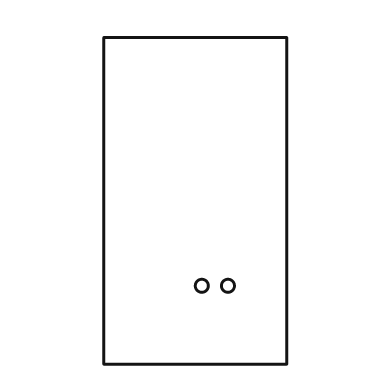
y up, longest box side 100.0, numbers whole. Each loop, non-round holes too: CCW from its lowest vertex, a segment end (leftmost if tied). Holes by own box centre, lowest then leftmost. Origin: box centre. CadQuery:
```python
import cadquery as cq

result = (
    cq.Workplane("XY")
    .moveTo(-28.0, -50.0)
    .lineTo(28.0, -50.0)
    .lineTo(28.0, 50.0)
    .lineTo(-28.0, 50.0)
    .close()
    .moveTo(2.0, -26.0)
    .circle(2.0)
    .moveTo(10.0, -26.0)
    .circle(2.0)
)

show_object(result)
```